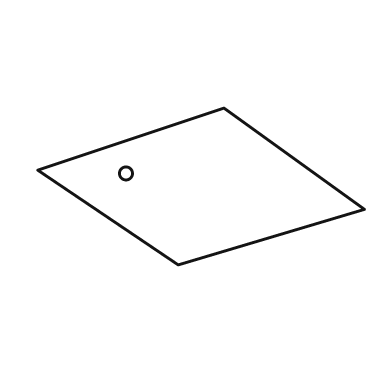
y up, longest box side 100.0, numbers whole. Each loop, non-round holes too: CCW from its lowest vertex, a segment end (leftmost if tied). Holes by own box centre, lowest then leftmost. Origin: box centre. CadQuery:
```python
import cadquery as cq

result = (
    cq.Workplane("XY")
    .moveTo(-7.0, -24.0)
    .lineTo(50.0, -7.0)
    .lineTo(7.0, 24.0)
    .lineTo(-50.0, 5.0)
    .close()
    .moveTo(-23.0, 4.0)
    .circle(2.0)
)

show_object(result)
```